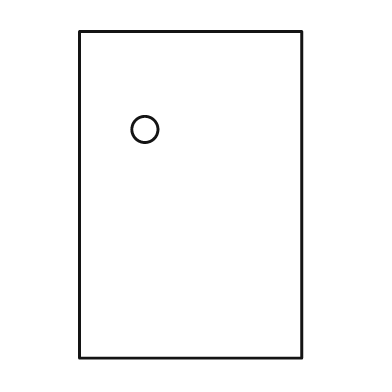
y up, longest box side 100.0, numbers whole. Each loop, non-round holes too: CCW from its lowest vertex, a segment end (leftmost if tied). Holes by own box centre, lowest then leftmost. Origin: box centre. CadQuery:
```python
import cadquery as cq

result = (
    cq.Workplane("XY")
    .moveTo(-34.0, -50.0)
    .lineTo(34.0, -50.0)
    .lineTo(34.0, 50.0)
    .lineTo(-34.0, 50.0)
    .close()
    .moveTo(-14.0, 20.0)
    .circle(4.0)
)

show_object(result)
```